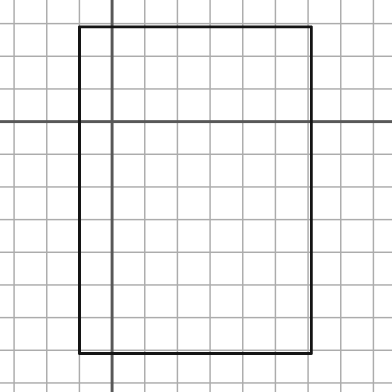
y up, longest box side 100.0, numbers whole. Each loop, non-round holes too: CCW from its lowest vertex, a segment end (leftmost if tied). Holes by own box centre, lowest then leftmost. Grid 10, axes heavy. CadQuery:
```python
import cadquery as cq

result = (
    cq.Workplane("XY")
    .moveTo(-10.0, -71.0)
    .lineTo(61.0, -71.0)
    .lineTo(61.0, 29.0)
    .lineTo(-10.0, 29.0)
    .close()
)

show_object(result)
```